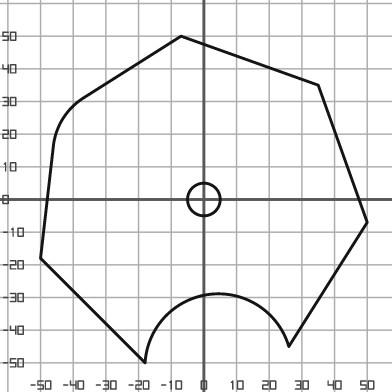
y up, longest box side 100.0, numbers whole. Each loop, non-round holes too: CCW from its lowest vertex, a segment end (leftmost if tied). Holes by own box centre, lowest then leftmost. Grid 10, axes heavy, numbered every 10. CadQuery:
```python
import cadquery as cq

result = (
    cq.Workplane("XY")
    .moveTo(-18.0, -50.0)
    .threePointArc((2.0, -29.0), (26.0, -45.0))
    .lineTo(50.0, -7.0)
    .lineTo(35.0, 35.0)
    .lineTo(-7.0, 50.0)
    .lineTo(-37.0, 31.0)
    .threePointArc((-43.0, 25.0), (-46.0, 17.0))
    .lineTo(-50.0, -18.0)
    .close()
    .moveTo(0.0, 0.0)
    .circle(5.0)
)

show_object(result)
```